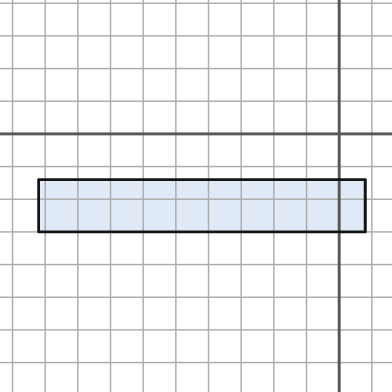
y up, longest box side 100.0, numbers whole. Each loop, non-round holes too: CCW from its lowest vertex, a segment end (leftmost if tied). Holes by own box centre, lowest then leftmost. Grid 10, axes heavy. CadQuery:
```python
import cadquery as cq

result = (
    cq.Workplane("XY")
    .moveTo(-92.0, -30.0)
    .lineTo(8.0, -30.0)
    .lineTo(8.0, -14.0)
    .lineTo(-92.0, -14.0)
    .close()
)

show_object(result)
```